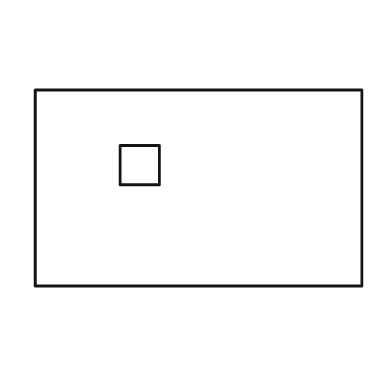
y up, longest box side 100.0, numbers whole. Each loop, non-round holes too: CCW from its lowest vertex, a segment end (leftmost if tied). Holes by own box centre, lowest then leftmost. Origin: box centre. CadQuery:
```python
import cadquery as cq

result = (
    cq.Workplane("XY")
    .moveTo(-50.0, -30.0)
    .lineTo(50.0, -30.0)
    .lineTo(50.0, 30.0)
    .lineTo(-50.0, 30.0)
    .close()
    .moveTo(-24.0, 1.0)
    .lineTo(-12.0, 1.0)
    .lineTo(-12.0, 13.0)
    .lineTo(-24.0, 13.0)
    .close()
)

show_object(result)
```